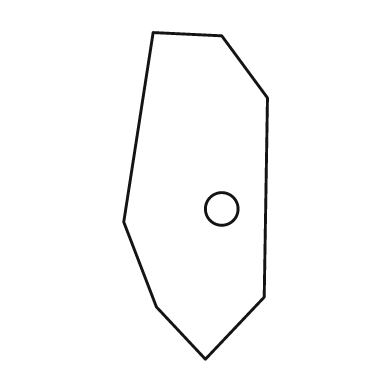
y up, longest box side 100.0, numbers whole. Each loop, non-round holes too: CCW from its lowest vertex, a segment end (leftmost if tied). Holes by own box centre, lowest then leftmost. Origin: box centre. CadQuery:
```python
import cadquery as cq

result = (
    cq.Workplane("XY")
    .moveTo(3.0, -50.0)
    .lineTo(21.0, -31.0)
    .lineTo(22.0, 30.0)
    .lineTo(8.0, 49.0)
    .lineTo(-13.0, 50.0)
    .lineTo(-22.0, -8.0)
    .lineTo(-12.0, -34.0)
    .close()
    .moveTo(8.0, -4.0)
    .circle(5.0)
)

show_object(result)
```